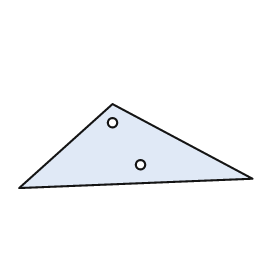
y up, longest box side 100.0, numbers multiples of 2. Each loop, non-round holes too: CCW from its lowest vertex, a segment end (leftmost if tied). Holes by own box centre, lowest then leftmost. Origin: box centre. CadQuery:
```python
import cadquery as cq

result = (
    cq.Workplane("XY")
    .moveTo(-50.0, -18.0)
    .lineTo(50.0, -14.0)
    .lineTo(-10.0, 18.0)
    .close()
    .moveTo(2.0, -8.0)
    .circle(2.0)
    .moveTo(-10.0, 10.0)
    .circle(2.0)
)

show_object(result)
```